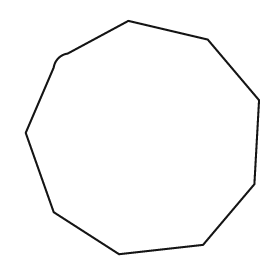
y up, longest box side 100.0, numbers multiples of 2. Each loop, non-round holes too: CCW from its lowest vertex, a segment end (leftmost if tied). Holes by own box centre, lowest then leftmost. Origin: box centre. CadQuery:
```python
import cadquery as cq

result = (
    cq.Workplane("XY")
    .moveTo(-10.0, -50.0)
    .lineTo(26.0, -46.0)
    .lineTo(48.0, -20.0)
    .lineTo(50.0, 16.0)
    .lineTo(28.0, 42.0)
    .lineTo(-6.0, 50.0)
    .lineTo(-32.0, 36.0)
    .threePointArc((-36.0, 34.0), (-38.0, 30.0))
    .lineTo(-50.0, 2.0)
    .lineTo(-38.0, -32.0)
    .close()
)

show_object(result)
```